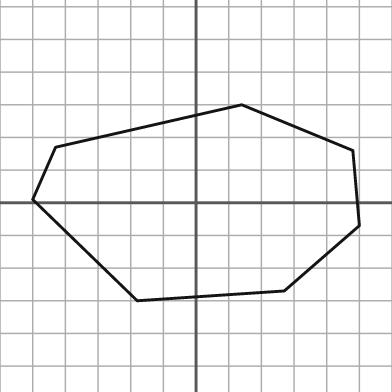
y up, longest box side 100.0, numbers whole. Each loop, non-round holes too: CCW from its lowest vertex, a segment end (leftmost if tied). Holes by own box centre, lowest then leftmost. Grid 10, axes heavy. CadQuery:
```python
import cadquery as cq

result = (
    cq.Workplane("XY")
    .moveTo(-18.0, -30.0)
    .lineTo(27.0, -27.0)
    .lineTo(50.0, -7.0)
    .lineTo(48.0, 16.0)
    .lineTo(14.0, 30.0)
    .lineTo(-43.0, 17.0)
    .lineTo(-50.0, 1.0)
    .close()
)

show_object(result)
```